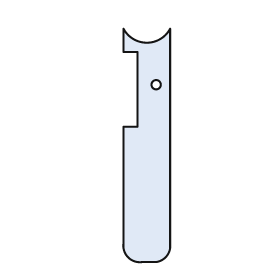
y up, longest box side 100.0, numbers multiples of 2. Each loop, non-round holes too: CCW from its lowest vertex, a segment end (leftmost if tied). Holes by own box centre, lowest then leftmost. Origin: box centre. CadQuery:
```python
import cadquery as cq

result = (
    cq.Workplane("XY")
    .moveTo(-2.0, -50.0)
    .lineTo(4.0, -50.0)
    .threePointArc((8.0, -48.0), (10.0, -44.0))
    .lineTo(10.0, 50.0)
    .threePointArc((0.0, 44.0), (-10.0, 50.0))
    .lineTo(-10.0, 40.0)
    .lineTo(-4.0, 40.0)
    .lineTo(-4.0, 8.0)
    .lineTo(-10.0, 8.0)
    .lineTo(-10.0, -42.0)
    .threePointArc((-8.0, -48.0), (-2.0, -50.0))
    .close()
    .moveTo(4.0, 26.0)
    .circle(2.0)
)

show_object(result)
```